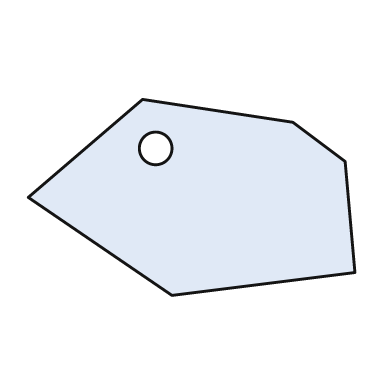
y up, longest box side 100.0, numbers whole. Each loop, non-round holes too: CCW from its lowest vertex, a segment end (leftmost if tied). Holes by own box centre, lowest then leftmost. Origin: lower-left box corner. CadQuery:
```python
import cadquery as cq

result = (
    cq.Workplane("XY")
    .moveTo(44.0, 0.0)
    .lineTo(100.0, 7.0)
    .lineTo(97.0, 41.0)
    .lineTo(81.0, 53.0)
    .lineTo(35.0, 60.0)
    .lineTo(0.0, 30.0)
    .close()
    .moveTo(39.0, 45.0)
    .circle(5.0)
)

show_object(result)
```